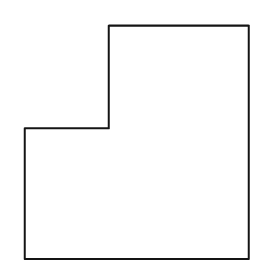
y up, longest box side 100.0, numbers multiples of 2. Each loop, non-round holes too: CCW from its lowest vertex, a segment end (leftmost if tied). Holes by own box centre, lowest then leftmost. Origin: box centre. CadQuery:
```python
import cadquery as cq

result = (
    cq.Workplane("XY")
    .moveTo(-48.0, -50.0)
    .lineTo(48.0, -50.0)
    .lineTo(48.0, 50.0)
    .lineTo(-12.0, 50.0)
    .lineTo(-12.0, 6.0)
    .lineTo(-48.0, 6.0)
    .close()
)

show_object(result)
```